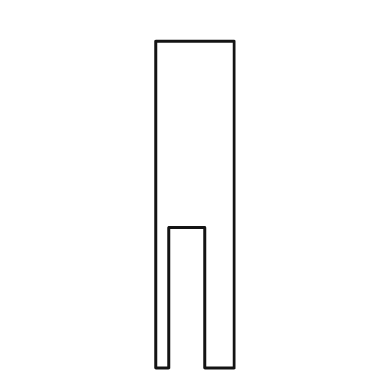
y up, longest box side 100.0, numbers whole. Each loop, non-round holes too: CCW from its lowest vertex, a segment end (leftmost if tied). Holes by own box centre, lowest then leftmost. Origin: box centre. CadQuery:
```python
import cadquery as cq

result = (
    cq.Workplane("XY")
    .moveTo(-12.0, -50.0)
    .lineTo(-8.0, -50.0)
    .lineTo(-8.0, -7.0)
    .lineTo(3.0, -7.0)
    .lineTo(3.0, -50.0)
    .lineTo(12.0, -50.0)
    .lineTo(12.0, 50.0)
    .lineTo(-12.0, 50.0)
    .close()
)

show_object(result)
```